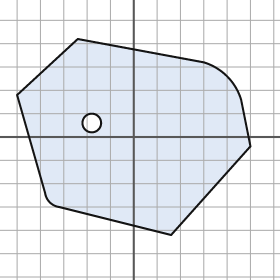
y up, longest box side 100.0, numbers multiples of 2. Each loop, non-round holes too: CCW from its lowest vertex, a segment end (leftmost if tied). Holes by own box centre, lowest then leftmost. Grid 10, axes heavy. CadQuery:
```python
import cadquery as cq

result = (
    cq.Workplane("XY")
    .moveTo(16.0, -42.0)
    .lineTo(50.0, -4.0)
    .lineTo(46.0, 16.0)
    .threePointArc((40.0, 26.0), (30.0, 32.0))
    .lineTo(-24.0, 42.0)
    .lineTo(-50.0, 18.0)
    .lineTo(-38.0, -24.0)
    .threePointArc((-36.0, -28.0), (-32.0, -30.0))
    .close()
    .moveTo(-18.0, 6.0)
    .circle(4.0)
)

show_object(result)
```